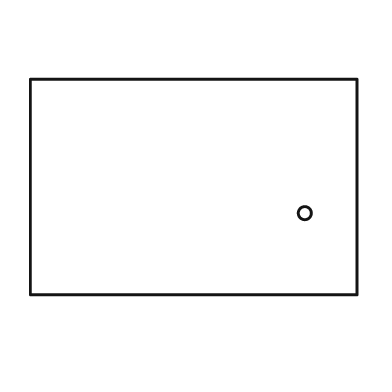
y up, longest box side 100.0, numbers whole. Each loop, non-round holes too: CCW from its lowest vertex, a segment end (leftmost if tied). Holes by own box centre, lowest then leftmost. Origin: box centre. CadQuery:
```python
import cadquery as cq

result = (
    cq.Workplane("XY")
    .moveTo(-50.0, -33.0)
    .lineTo(50.0, -33.0)
    .lineTo(50.0, 33.0)
    .lineTo(-50.0, 33.0)
    .close()
    .moveTo(34.0, -8.0)
    .circle(2.0)
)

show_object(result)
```